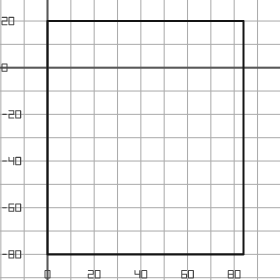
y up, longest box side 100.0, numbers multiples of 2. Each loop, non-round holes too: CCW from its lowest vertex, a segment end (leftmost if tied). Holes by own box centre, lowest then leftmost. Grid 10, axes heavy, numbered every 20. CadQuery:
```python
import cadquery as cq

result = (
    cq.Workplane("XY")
    .moveTo(0.0, -80.0)
    .lineTo(84.0, -80.0)
    .lineTo(84.0, 20.0)
    .lineTo(0.0, 20.0)
    .close()
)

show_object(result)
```